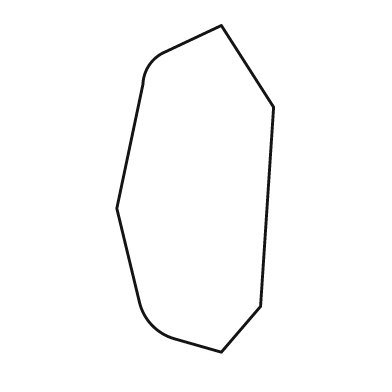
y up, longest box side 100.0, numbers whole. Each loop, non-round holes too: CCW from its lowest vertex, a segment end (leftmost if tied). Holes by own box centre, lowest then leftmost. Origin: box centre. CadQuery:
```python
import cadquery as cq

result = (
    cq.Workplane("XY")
    .moveTo(8.0, -50.0)
    .lineTo(20.0, -36.0)
    .lineTo(24.0, 25.0)
    .lineTo(8.0, 50.0)
    .lineTo(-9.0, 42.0)
    .threePointArc((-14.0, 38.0), (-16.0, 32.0))
    .lineTo(-24.0, -6.0)
    .lineTo(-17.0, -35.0)
    .threePointArc((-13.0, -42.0), (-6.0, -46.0))
    .close()
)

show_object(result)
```